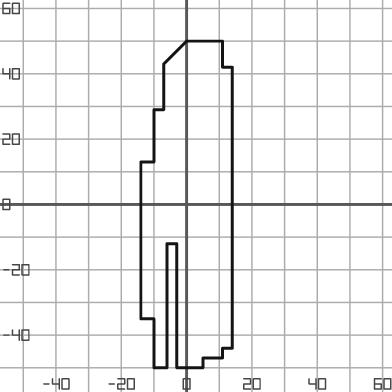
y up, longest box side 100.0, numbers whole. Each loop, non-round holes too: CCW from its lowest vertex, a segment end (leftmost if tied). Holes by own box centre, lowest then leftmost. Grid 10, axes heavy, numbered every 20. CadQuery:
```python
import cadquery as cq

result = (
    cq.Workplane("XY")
    .moveTo(-10.0, -50.0)
    .lineTo(-6.0, -50.0)
    .lineTo(-6.0, -12.0)
    .lineTo(-3.0, -12.0)
    .lineTo(-3.0, -50.0)
    .lineTo(5.0, -50.0)
    .lineTo(5.0, -47.0)
    .lineTo(11.0, -47.0)
    .lineTo(11.0, -44.0)
    .lineTo(14.0, -44.0)
    .lineTo(14.0, 42.0)
    .lineTo(11.0, 42.0)
    .lineTo(11.0, 50.0)
    .lineTo(0.0, 50.0)
    .lineTo(-7.0, 43.0)
    .lineTo(-7.0, 29.0)
    .lineTo(-10.0, 29.0)
    .lineTo(-10.0, 13.0)
    .lineTo(-14.0, 13.0)
    .lineTo(-14.0, -35.0)
    .lineTo(-10.0, -35.0)
    .close()
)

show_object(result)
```